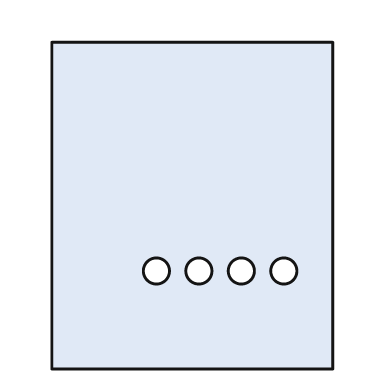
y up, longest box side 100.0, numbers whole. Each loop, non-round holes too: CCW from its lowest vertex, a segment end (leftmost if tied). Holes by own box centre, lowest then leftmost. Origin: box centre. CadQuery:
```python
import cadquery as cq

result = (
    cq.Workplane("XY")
    .moveTo(-43.0, -50.0)
    .lineTo(43.0, -50.0)
    .lineTo(43.0, 50.0)
    .lineTo(-43.0, 50.0)
    .close()
    .moveTo(-11.0, -20.0)
    .circle(4.0)
    .moveTo(2.0, -20.0)
    .circle(4.0)
    .moveTo(15.0, -20.0)
    .circle(4.0)
    .moveTo(28.0, -20.0)
    .circle(4.0)
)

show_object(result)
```